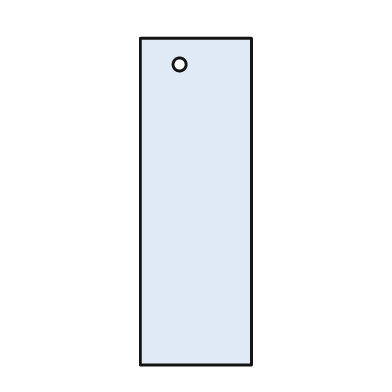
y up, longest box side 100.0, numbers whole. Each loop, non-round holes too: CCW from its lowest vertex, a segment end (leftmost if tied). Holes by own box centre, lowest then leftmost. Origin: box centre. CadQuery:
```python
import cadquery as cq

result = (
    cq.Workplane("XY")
    .moveTo(-17.0, -50.0)
    .lineTo(17.0, -50.0)
    .lineTo(17.0, 50.0)
    .lineTo(-17.0, 50.0)
    .close()
    .moveTo(-5.0, 42.0)
    .circle(2.0)
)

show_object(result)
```